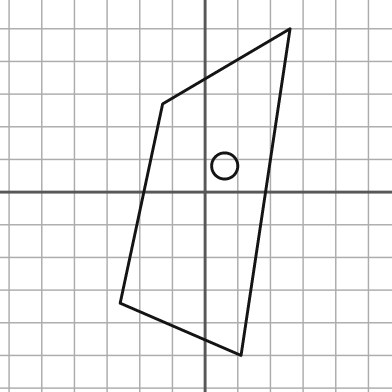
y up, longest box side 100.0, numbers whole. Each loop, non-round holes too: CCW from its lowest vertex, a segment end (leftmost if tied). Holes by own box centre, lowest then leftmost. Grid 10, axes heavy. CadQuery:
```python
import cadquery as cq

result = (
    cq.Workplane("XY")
    .moveTo(11.0, -50.0)
    .lineTo(26.0, 50.0)
    .lineTo(-13.0, 27.0)
    .lineTo(-26.0, -34.0)
    .close()
    .moveTo(6.0, 8.0)
    .circle(4.0)
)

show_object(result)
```